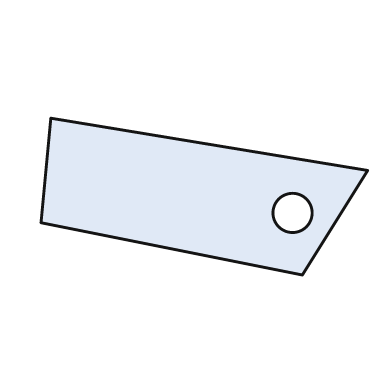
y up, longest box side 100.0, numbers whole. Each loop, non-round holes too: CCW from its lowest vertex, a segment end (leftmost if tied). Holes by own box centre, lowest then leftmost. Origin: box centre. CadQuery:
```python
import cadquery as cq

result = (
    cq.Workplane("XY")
    .moveTo(30.0, -24.0)
    .lineTo(50.0, 8.0)
    .lineTo(-47.0, 24.0)
    .lineTo(-50.0, -8.0)
    .close()
    .moveTo(27.0, -5.0)
    .circle(6.0)
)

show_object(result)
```